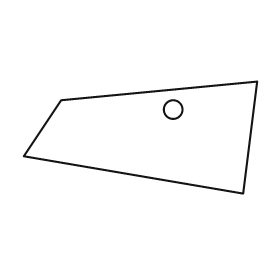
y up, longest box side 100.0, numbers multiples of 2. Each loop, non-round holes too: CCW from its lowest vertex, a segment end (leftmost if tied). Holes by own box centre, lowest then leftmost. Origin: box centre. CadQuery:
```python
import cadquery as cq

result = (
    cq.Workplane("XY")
    .moveTo(44.0, -24.0)
    .lineTo(50.0, 24.0)
    .lineTo(-34.0, 16.0)
    .lineTo(-50.0, -8.0)
    .close()
    .moveTo(14.0, 12.0)
    .circle(4.0)
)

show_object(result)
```